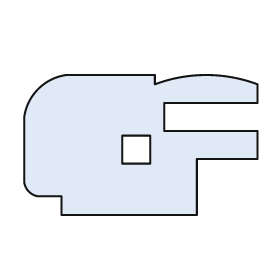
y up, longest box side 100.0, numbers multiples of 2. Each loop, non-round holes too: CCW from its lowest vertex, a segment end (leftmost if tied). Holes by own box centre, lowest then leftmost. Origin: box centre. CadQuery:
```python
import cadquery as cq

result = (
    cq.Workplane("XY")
    .moveTo(-34.0, -30.0)
    .lineTo(24.0, -30.0)
    .lineTo(24.0, -6.0)
    .lineTo(50.0, -6.0)
    .lineTo(50.0, 6.0)
    .lineTo(10.0, 6.0)
    .lineTo(10.0, 18.0)
    .lineTo(50.0, 18.0)
    .lineTo(50.0, 26.0)
    .threePointArc((28.0, 30.0), (6.0, 26.0))
    .lineTo(6.0, 30.0)
    .lineTo(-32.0, 30.0)
    .threePointArc((-44.0, 24.0), (-50.0, 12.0))
    .lineTo(-50.0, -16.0)
    .threePointArc((-48.0, -20.0), (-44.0, -22.0))
    .lineTo(-34.0, -22.0)
    .close()
    .moveTo(-8.0, -8.0)
    .lineTo(4.0, -8.0)
    .lineTo(4.0, 4.0)
    .lineTo(-8.0, 4.0)
    .close()
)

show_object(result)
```